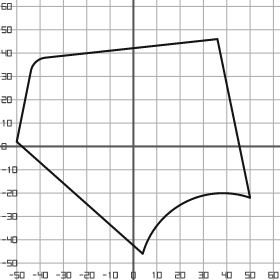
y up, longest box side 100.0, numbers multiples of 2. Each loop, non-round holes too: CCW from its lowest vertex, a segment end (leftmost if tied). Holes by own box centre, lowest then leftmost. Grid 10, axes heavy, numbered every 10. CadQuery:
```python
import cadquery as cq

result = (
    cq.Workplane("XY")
    .moveTo(4.0, -46.0)
    .threePointArc((22.0, -24.0), (50.0, -22.0))
    .lineTo(36.0, 46.0)
    .lineTo(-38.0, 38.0)
    .threePointArc((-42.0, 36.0), (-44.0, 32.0))
    .lineTo(-50.0, 2.0)
    .close()
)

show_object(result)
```